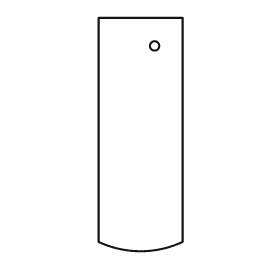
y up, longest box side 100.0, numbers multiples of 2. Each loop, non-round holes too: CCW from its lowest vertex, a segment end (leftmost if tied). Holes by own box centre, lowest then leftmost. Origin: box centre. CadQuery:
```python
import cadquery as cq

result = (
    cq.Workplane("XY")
    .moveTo(-18.0, -46.0)
    .threePointArc((0.0, -50.0), (18.0, -46.0))
    .lineTo(18.0, 50.0)
    .lineTo(-18.0, 50.0)
    .close()
    .moveTo(6.0, 38.0)
    .circle(2.0)
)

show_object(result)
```